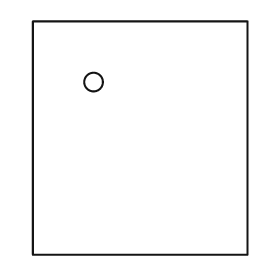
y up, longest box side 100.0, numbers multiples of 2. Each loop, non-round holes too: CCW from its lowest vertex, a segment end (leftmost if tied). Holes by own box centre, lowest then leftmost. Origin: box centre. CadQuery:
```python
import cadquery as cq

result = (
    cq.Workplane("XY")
    .moveTo(-46.0, -50.0)
    .lineTo(46.0, -50.0)
    .lineTo(46.0, 50.0)
    .lineTo(-46.0, 50.0)
    .close()
    .moveTo(-20.0, 24.0)
    .circle(4.0)
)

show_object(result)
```